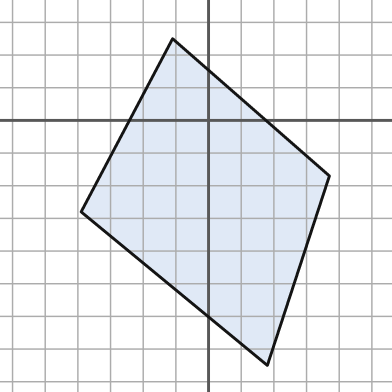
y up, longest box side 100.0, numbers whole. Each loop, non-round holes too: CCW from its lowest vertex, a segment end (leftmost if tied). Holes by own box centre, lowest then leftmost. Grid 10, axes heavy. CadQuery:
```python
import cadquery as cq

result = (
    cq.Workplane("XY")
    .moveTo(18.0, -75.0)
    .lineTo(37.0, -17.0)
    .lineTo(-11.0, 25.0)
    .lineTo(-39.0, -28.0)
    .close()
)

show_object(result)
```